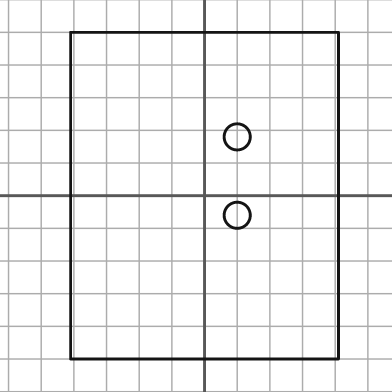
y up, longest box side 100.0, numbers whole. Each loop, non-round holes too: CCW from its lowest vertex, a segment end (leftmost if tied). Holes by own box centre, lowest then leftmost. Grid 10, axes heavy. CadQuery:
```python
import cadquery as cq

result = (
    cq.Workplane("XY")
    .moveTo(-41.0, -50.0)
    .lineTo(41.0, -50.0)
    .lineTo(41.0, 50.0)
    .lineTo(-41.0, 50.0)
    .close()
    .moveTo(10.0, -6.0)
    .circle(4.0)
    .moveTo(10.0, 18.0)
    .circle(4.0)
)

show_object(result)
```